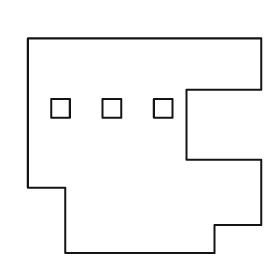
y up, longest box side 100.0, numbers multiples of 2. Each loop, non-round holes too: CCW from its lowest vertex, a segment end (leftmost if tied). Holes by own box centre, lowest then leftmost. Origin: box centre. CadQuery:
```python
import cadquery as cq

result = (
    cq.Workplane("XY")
    .moveTo(-34.0, -46.0)
    .lineTo(30.0, -46.0)
    .lineTo(30.0, -34.0)
    .lineTo(50.0, -34.0)
    .lineTo(50.0, -6.0)
    .lineTo(18.0, -6.0)
    .lineTo(18.0, 24.0)
    .lineTo(50.0, 24.0)
    .lineTo(50.0, 46.0)
    .lineTo(-50.0, 46.0)
    .lineTo(-50.0, -18.0)
    .lineTo(-34.0, -18.0)
    .close()
    .moveTo(-40.0, 12.0)
    .lineTo(-32.0, 12.0)
    .lineTo(-32.0, 20.0)
    .lineTo(-40.0, 20.0)
    .close()
    .moveTo(-18.0, 12.0)
    .lineTo(-10.0, 12.0)
    .lineTo(-10.0, 20.0)
    .lineTo(-18.0, 20.0)
    .close()
    .moveTo(4.0, 12.0)
    .lineTo(12.0, 12.0)
    .lineTo(12.0, 20.0)
    .lineTo(4.0, 20.0)
    .close()
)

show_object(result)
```